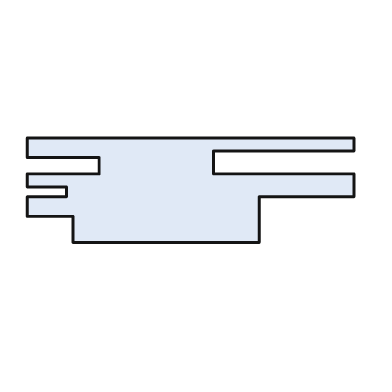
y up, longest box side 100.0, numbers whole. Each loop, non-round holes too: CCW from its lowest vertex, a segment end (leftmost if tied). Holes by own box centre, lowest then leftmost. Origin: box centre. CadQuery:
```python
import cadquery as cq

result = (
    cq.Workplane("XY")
    .moveTo(-36.0, -16.0)
    .lineTo(21.0, -16.0)
    .lineTo(21.0, -2.0)
    .lineTo(50.0, -2.0)
    .lineTo(50.0, 5.0)
    .lineTo(7.0, 5.0)
    .lineTo(7.0, 12.0)
    .lineTo(50.0, 12.0)
    .lineTo(50.0, 16.0)
    .lineTo(-50.0, 16.0)
    .lineTo(-50.0, 10.0)
    .lineTo(-28.0, 10.0)
    .lineTo(-28.0, 5.0)
    .lineTo(-50.0, 5.0)
    .lineTo(-50.0, 1.0)
    .lineTo(-38.0, 1.0)
    .lineTo(-38.0, -2.0)
    .lineTo(-50.0, -2.0)
    .lineTo(-50.0, -8.0)
    .lineTo(-36.0, -8.0)
    .close()
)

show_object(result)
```